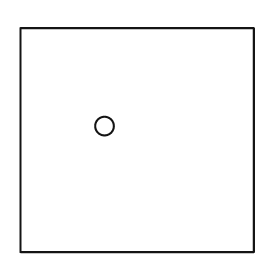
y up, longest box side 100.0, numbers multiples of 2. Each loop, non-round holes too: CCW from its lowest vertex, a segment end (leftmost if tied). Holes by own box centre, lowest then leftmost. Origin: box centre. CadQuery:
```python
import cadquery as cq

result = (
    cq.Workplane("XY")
    .moveTo(-50.0, -48.0)
    .lineTo(50.0, -48.0)
    .lineTo(50.0, 48.0)
    .lineTo(-50.0, 48.0)
    .close()
    .moveTo(-14.0, 6.0)
    .circle(4.0)
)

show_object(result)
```